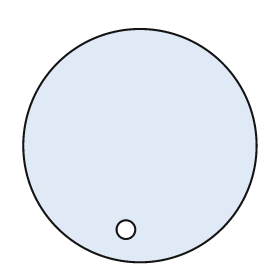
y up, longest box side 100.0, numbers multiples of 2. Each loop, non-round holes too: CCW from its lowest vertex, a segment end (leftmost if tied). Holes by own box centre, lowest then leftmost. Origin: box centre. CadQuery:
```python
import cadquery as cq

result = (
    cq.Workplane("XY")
    .moveTo(0.0, 0.0)
    .circle(50.0)
    .moveTo(-6.0, -36.0)
    .circle(4.0)
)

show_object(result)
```